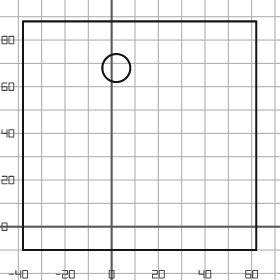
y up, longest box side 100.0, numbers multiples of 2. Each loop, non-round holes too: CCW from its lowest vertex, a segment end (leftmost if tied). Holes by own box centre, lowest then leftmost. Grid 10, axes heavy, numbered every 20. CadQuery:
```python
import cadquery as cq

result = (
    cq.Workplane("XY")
    .moveTo(-38.0, -10.0)
    .lineTo(62.0, -10.0)
    .lineTo(62.0, 88.0)
    .lineTo(-38.0, 88.0)
    .close()
    .moveTo(2.0, 68.0)
    .circle(6.0)
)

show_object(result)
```